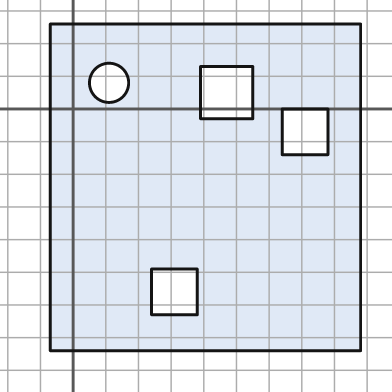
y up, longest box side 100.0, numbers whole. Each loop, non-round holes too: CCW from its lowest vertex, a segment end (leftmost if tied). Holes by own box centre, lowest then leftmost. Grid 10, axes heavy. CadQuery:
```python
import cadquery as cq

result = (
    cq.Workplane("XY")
    .moveTo(-7.0, -74.0)
    .lineTo(88.0, -74.0)
    .lineTo(88.0, 26.0)
    .lineTo(-7.0, 26.0)
    .close()
    .moveTo(24.0, -63.0)
    .lineTo(38.0, -63.0)
    .lineTo(38.0, -49.0)
    .lineTo(24.0, -49.0)
    .close()
    .moveTo(64.0, -14.0)
    .lineTo(78.0, -14.0)
    .lineTo(78.0, 0.0)
    .lineTo(64.0, 0.0)
    .close()
    .moveTo(39.0, -3.0)
    .lineTo(55.0, -3.0)
    .lineTo(55.0, 13.0)
    .lineTo(39.0, 13.0)
    .close()
    .moveTo(11.0, 8.0)
    .circle(6.0)
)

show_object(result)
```